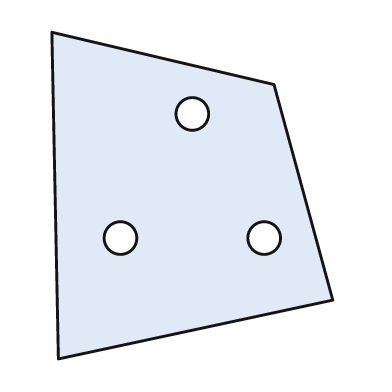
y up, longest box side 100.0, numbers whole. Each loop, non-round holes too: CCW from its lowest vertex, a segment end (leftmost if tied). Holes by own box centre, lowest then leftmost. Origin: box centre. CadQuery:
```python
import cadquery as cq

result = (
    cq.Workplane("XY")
    .moveTo(-41.0, -50.0)
    .lineTo(43.0, -32.0)
    .lineTo(25.0, 34.0)
    .lineTo(-43.0, 50.0)
    .close()
    .moveTo(-22.0, -13.0)
    .circle(5.0)
    .moveTo(22.0, -13.0)
    .circle(5.0)
    .moveTo(0.0, 25.0)
    .circle(5.0)
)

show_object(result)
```